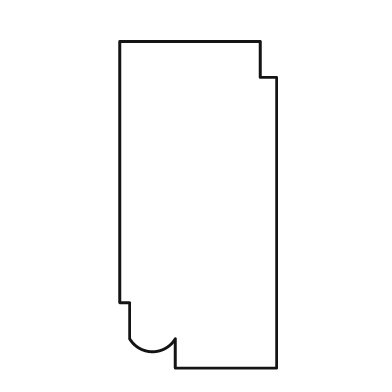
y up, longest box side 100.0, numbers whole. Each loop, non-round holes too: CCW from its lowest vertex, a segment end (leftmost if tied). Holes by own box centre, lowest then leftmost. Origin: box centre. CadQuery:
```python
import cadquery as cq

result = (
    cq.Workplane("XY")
    .moveTo(-7.0, -50.0)
    .lineTo(24.0, -50.0)
    .lineTo(24.0, 39.0)
    .lineTo(19.0, 39.0)
    .lineTo(19.0, 50.0)
    .lineTo(-24.0, 50.0)
    .lineTo(-24.0, -30.0)
    .lineTo(-21.0, -30.0)
    .lineTo(-21.0, -41.0)
    .threePointArc((-14.0, -45.0), (-7.0, -41.0))
    .close()
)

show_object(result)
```